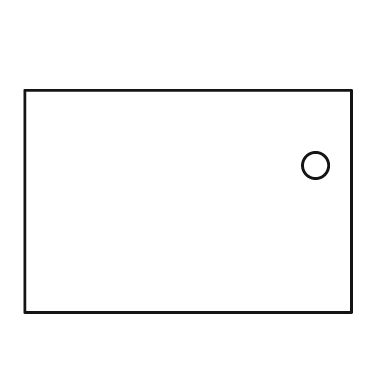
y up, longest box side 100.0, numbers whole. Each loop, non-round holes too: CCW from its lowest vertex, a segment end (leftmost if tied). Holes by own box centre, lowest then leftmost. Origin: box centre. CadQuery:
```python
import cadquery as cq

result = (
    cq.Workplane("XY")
    .moveTo(-50.0, -34.0)
    .lineTo(50.0, -34.0)
    .lineTo(50.0, 34.0)
    .lineTo(-50.0, 34.0)
    .close()
    .moveTo(39.0, 11.0)
    .circle(4.0)
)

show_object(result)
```